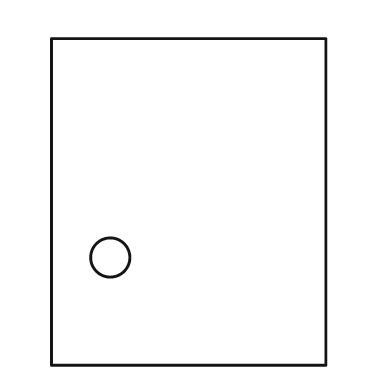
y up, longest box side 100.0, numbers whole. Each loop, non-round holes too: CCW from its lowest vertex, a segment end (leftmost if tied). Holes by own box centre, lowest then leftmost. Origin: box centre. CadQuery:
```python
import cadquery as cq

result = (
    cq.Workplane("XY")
    .moveTo(-42.0, -50.0)
    .lineTo(42.0, -50.0)
    .lineTo(42.0, 50.0)
    .lineTo(-42.0, 50.0)
    .close()
    .moveTo(-24.0, -17.0)
    .circle(6.0)
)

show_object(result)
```